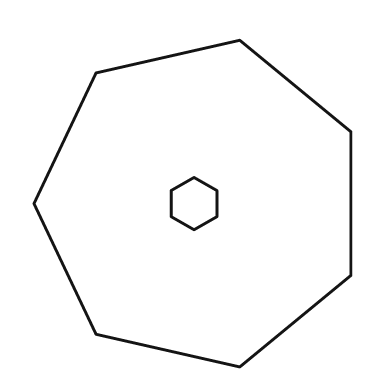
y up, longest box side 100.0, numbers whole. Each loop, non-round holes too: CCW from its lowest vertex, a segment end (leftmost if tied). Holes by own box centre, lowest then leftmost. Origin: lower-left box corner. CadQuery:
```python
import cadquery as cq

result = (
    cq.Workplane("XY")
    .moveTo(63.0, 0.0)
    .lineTo(97.0, 28.0)
    .lineTo(97.0, 72.0)
    .lineTo(63.0, 100.0)
    .lineTo(19.0, 90.0)
    .lineTo(0.0, 50.0)
    .lineTo(19.0, 10.0)
    .close()
    .moveTo(49.0, 42.0)
    .lineTo(56.0, 46.0)
    .lineTo(56.0, 54.0)
    .lineTo(49.0, 58.0)
    .lineTo(42.0, 54.0)
    .lineTo(42.0, 46.0)
    .close()
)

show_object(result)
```